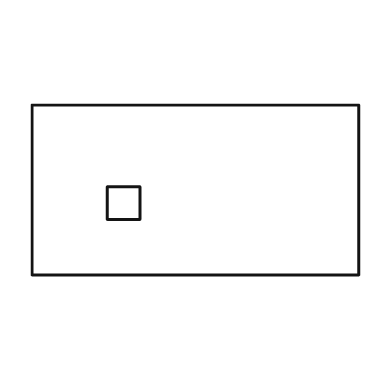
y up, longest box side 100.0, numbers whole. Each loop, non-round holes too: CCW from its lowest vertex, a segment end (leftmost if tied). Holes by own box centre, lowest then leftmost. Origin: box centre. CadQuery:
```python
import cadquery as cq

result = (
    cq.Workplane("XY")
    .moveTo(-50.0, -26.0)
    .lineTo(50.0, -26.0)
    .lineTo(50.0, 26.0)
    .lineTo(-50.0, 26.0)
    .close()
    .moveTo(-27.0, -9.0)
    .lineTo(-17.0, -9.0)
    .lineTo(-17.0, 1.0)
    .lineTo(-27.0, 1.0)
    .close()
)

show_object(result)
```